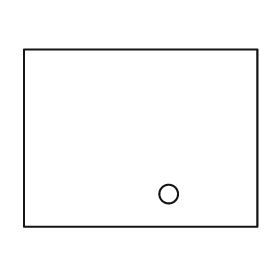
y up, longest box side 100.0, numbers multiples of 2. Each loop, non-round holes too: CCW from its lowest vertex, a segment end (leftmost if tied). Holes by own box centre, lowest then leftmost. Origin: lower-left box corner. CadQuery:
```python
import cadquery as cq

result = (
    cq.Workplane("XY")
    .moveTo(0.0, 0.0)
    .lineTo(100.0, 0.0)
    .lineTo(100.0, 76.0)
    .lineTo(0.0, 76.0)
    .close()
    .moveTo(62.0, 14.0)
    .circle(4.0)
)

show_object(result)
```